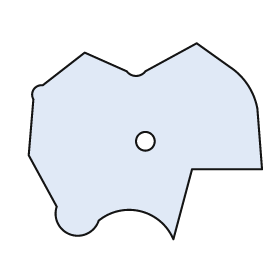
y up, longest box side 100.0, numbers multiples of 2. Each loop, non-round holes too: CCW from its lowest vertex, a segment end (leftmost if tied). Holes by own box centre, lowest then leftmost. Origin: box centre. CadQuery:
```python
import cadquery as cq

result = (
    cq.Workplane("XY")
    .moveTo(12.0, -42.0)
    .lineTo(20.0, -12.0)
    .lineTo(50.0, -12.0)
    .lineTo(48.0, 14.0)
    .threePointArc((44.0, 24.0), (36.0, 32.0))
    .lineTo(22.0, 42.0)
    .lineTo(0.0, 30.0)
    .threePointArc((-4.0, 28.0), (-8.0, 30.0))
    .lineTo(-26.0, 38.0)
    .lineTo(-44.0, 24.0)
    .threePointArc((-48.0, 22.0), (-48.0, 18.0))
    .lineTo(-50.0, -6.0)
    .lineTo(-38.0, -28.0)
    .threePointArc((-32.0, -40.0), (-20.0, -34.0))
    .threePointArc((-2.0, -30.0), (12.0, -42.0))
    .close()
    .moveTo(0.0, 0.0)
    .circle(4.0)
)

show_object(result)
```